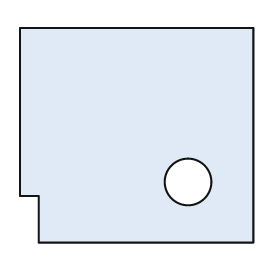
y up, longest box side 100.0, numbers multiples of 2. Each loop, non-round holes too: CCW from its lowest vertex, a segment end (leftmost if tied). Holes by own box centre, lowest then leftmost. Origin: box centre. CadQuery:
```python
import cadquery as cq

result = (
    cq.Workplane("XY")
    .moveTo(-42.0, -46.0)
    .lineTo(50.0, -46.0)
    .lineTo(50.0, 46.0)
    .lineTo(-50.0, 46.0)
    .lineTo(-50.0, -26.0)
    .lineTo(-42.0, -26.0)
    .close()
    .moveTo(22.0, -20.0)
    .circle(10.0)
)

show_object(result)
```